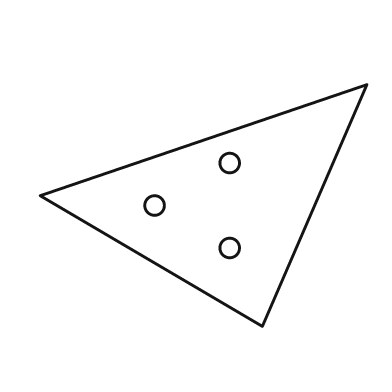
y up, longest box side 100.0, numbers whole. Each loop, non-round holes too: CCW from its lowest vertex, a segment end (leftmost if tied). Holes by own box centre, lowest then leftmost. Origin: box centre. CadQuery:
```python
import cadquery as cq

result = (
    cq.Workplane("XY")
    .moveTo(18.0, -37.0)
    .lineTo(50.0, 37.0)
    .lineTo(-50.0, 3.0)
    .close()
    .moveTo(8.0, -13.0)
    .circle(3.0)
    .moveTo(-15.0, 0.0)
    .circle(3.0)
    .moveTo(8.0, 13.0)
    .circle(3.0)
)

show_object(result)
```